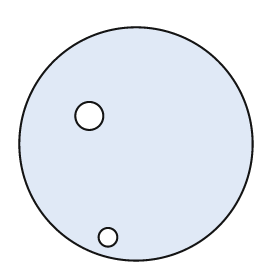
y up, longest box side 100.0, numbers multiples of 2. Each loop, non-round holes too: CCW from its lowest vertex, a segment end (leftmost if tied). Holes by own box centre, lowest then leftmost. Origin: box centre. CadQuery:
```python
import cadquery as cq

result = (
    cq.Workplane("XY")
    .moveTo(0.0, 0.0)
    .circle(50.0)
    .moveTo(-12.0, -40.0)
    .circle(4.0)
    .moveTo(-20.0, 12.0)
    .circle(6.0)
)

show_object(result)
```